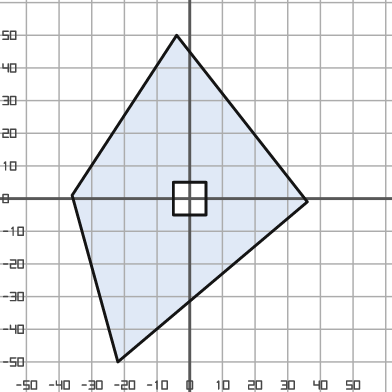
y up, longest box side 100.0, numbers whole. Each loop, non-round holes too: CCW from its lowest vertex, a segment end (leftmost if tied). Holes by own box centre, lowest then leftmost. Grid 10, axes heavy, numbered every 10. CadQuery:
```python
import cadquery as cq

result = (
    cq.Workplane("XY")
    .moveTo(-22.0, -50.0)
    .lineTo(36.0, -1.0)
    .lineTo(-4.0, 50.0)
    .lineTo(-36.0, 1.0)
    .close()
    .moveTo(-5.0, -5.0)
    .lineTo(5.0, -5.0)
    .lineTo(5.0, 5.0)
    .lineTo(-5.0, 5.0)
    .close()
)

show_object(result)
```